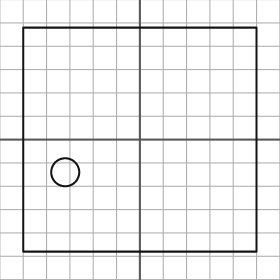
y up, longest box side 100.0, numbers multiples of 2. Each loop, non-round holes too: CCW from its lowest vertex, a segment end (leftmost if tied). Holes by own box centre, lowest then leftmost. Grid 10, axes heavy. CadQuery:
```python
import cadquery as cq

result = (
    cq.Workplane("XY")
    .moveTo(-50.0, -48.0)
    .lineTo(50.0, -48.0)
    .lineTo(50.0, 48.0)
    .lineTo(-50.0, 48.0)
    .close()
    .moveTo(-32.0, -14.0)
    .circle(6.0)
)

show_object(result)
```